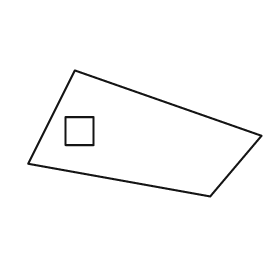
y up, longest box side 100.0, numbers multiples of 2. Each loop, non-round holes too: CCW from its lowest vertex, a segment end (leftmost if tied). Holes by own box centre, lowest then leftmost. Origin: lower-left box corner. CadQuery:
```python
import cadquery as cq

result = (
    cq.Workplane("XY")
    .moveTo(78.0, 0.0)
    .lineTo(100.0, 26.0)
    .lineTo(20.0, 54.0)
    .lineTo(0.0, 14.0)
    .close()
    .moveTo(16.0, 22.0)
    .lineTo(28.0, 22.0)
    .lineTo(28.0, 34.0)
    .lineTo(16.0, 34.0)
    .close()
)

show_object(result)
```